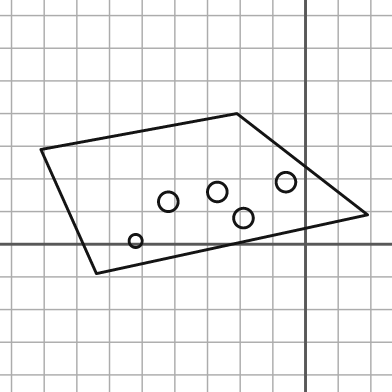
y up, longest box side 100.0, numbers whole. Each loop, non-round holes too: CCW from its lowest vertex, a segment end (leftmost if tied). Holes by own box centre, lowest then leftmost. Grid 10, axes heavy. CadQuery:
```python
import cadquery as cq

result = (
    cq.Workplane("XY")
    .moveTo(-64.0, -9.0)
    .lineTo(19.0, 9.0)
    .lineTo(-21.0, 40.0)
    .lineTo(-81.0, 29.0)
    .close()
    .moveTo(-52.0, 1.0)
    .circle(2.0)
    .moveTo(-19.0, 8.0)
    .circle(3.0)
    .moveTo(-42.0, 13.0)
    .circle(3.0)
    .moveTo(-27.0, 16.0)
    .circle(3.0)
    .moveTo(-6.0, 19.0)
    .circle(3.0)
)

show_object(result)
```